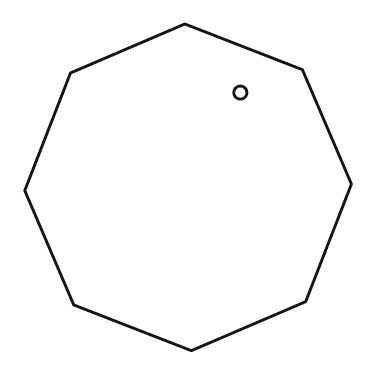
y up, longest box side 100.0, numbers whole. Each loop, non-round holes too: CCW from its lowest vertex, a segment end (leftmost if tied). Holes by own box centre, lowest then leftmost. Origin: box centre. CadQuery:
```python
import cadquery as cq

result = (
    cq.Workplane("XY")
    .moveTo(1.0, -50.0)
    .lineTo(36.0, -35.0)
    .lineTo(50.0, 1.0)
    .lineTo(35.0, 36.0)
    .lineTo(-1.0, 50.0)
    .lineTo(-36.0, 35.0)
    .lineTo(-50.0, -1.0)
    .lineTo(-35.0, -36.0)
    .close()
    .moveTo(16.0, 29.0)
    .circle(2.0)
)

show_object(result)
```